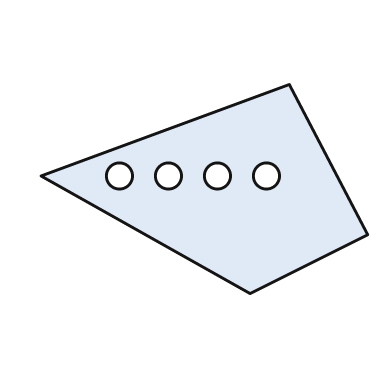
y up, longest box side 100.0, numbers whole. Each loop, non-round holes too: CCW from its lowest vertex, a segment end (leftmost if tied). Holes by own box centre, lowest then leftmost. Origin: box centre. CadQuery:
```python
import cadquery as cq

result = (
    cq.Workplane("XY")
    .moveTo(14.0, -32.0)
    .lineTo(50.0, -14.0)
    .lineTo(26.0, 32.0)
    .lineTo(-50.0, 4.0)
    .close()
    .moveTo(-26.0, 4.0)
    .circle(4.0)
    .moveTo(-11.0, 4.0)
    .circle(4.0)
    .moveTo(4.0, 4.0)
    .circle(4.0)
    .moveTo(19.0, 4.0)
    .circle(4.0)
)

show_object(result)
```